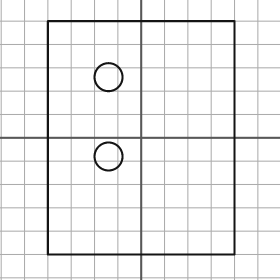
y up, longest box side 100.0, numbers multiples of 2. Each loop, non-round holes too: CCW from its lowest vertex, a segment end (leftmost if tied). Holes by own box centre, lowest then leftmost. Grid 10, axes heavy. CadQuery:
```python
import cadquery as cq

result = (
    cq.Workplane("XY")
    .moveTo(-40.0, -50.0)
    .lineTo(40.0, -50.0)
    .lineTo(40.0, 50.0)
    .lineTo(-40.0, 50.0)
    .close()
    .moveTo(-14.0, -8.0)
    .circle(6.0)
    .moveTo(-14.0, 26.0)
    .circle(6.0)
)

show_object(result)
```